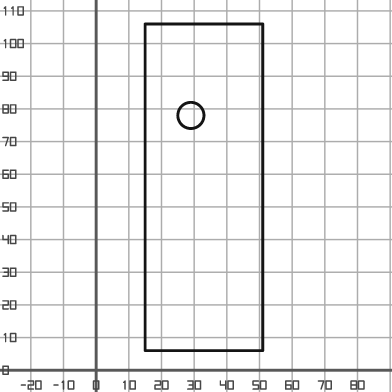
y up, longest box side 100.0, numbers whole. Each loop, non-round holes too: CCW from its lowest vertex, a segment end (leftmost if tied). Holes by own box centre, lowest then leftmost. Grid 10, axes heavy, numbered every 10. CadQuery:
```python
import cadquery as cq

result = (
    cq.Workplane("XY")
    .moveTo(15.0, 6.0)
    .lineTo(51.0, 6.0)
    .lineTo(51.0, 106.0)
    .lineTo(15.0, 106.0)
    .close()
    .moveTo(29.0, 78.0)
    .circle(4.0)
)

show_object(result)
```